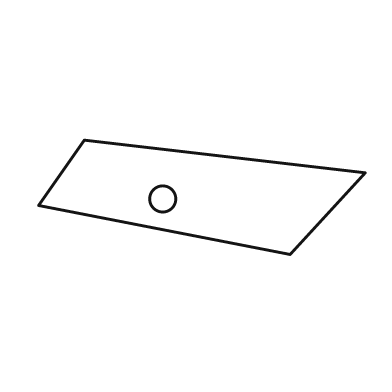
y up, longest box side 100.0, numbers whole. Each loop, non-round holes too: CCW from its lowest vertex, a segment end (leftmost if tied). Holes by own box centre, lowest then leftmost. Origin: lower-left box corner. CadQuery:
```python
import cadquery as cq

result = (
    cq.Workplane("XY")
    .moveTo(77.0, 0.0)
    .lineTo(100.0, 25.0)
    .lineTo(14.0, 35.0)
    .lineTo(0.0, 15.0)
    .close()
    .moveTo(38.0, 17.0)
    .circle(4.0)
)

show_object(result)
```